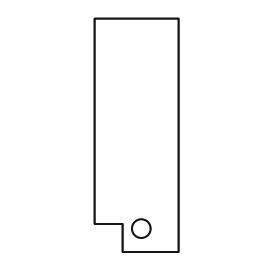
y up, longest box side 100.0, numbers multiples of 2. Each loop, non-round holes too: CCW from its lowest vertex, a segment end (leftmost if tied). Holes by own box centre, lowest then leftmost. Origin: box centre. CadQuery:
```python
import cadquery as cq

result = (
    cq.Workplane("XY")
    .moveTo(-6.0, -50.0)
    .lineTo(18.0, -50.0)
    .lineTo(18.0, 50.0)
    .lineTo(-18.0, 50.0)
    .lineTo(-18.0, -38.0)
    .lineTo(-6.0, -38.0)
    .close()
    .moveTo(2.0, -40.0)
    .circle(4.0)
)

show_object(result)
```